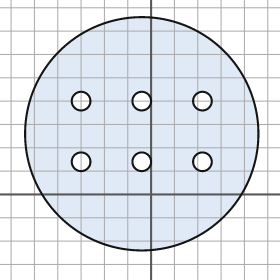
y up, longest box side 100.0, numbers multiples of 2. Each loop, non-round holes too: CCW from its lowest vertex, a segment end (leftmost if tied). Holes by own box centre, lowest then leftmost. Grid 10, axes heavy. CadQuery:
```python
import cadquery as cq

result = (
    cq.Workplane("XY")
    .moveTo(-4.0, 26.0)
    .circle(50.0)
    .moveTo(-30.0, 14.0)
    .circle(4.0)
    .moveTo(-4.0, 14.0)
    .circle(4.0)
    .moveTo(22.0, 14.0)
    .circle(4.0)
    .moveTo(-30.0, 40.0)
    .circle(4.0)
    .moveTo(-4.0, 40.0)
    .circle(4.0)
    .moveTo(22.0, 40.0)
    .circle(4.0)
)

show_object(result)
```